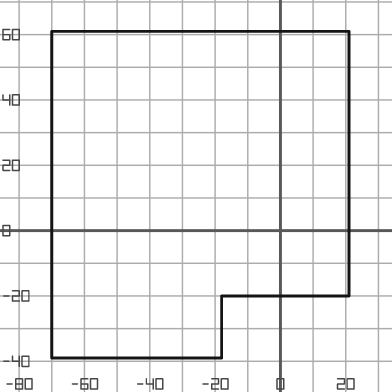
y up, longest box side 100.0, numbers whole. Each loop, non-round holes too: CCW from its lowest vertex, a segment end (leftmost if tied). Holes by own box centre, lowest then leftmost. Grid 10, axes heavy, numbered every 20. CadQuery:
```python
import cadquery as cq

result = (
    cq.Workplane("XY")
    .moveTo(-70.0, -39.0)
    .lineTo(-18.0, -39.0)
    .lineTo(-18.0, -20.0)
    .lineTo(21.0, -20.0)
    .lineTo(21.0, 61.0)
    .lineTo(-70.0, 61.0)
    .close()
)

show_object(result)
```